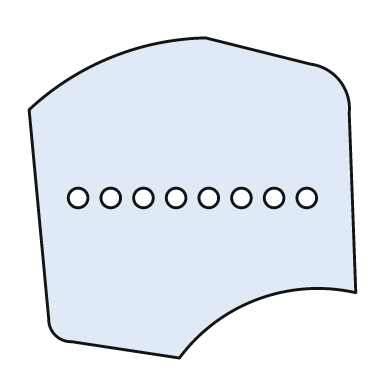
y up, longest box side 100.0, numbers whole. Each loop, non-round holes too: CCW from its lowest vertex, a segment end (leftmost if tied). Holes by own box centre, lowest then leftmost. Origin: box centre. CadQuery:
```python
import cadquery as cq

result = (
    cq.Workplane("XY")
    .moveTo(-4.0, -49.0)
    .threePointArc((20.0, -31.0), (50.0, -29.0))
    .lineTo(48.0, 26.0)
    .threePointArc((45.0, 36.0), (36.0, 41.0))
    .lineTo(4.0, 49.0)
    .threePointArc((-25.0, 43.0), (-50.0, 27.0))
    .lineTo(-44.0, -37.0)
    .threePointArc((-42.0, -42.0), (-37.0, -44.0))
    .close()
    .moveTo(-35.0, 0.0)
    .circle(3.0)
    .moveTo(-25.0, 0.0)
    .circle(3.0)
    .moveTo(-15.0, 0.0)
    .circle(3.0)
    .moveTo(-5.0, 0.0)
    .circle(3.0)
    .moveTo(5.0, 0.0)
    .circle(3.0)
    .moveTo(15.0, 0.0)
    .circle(3.0)
    .moveTo(25.0, 0.0)
    .circle(3.0)
    .moveTo(35.0, 0.0)
    .circle(3.0)
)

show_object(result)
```